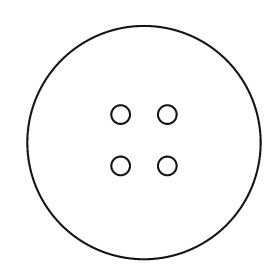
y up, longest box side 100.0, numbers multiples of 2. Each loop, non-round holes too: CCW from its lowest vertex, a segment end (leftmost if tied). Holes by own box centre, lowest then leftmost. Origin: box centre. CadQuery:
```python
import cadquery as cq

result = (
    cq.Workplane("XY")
    .moveTo(0.0, 0.0)
    .circle(50.0)
    .moveTo(-10.0, -10.0)
    .circle(4.0)
    .moveTo(10.0, -10.0)
    .circle(4.0)
    .moveTo(-10.0, 12.0)
    .circle(4.0)
    .moveTo(10.0, 12.0)
    .circle(4.0)
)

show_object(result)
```